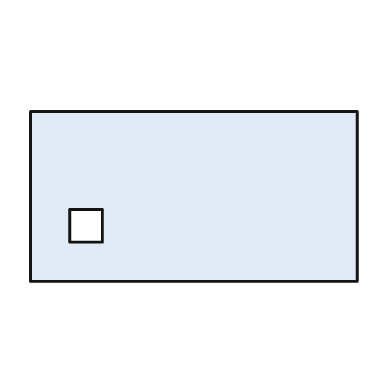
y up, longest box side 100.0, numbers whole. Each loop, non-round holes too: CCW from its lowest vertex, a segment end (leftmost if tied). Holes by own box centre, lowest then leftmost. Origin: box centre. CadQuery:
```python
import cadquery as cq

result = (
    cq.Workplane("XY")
    .moveTo(-50.0, -26.0)
    .lineTo(50.0, -26.0)
    .lineTo(50.0, 26.0)
    .lineTo(-50.0, 26.0)
    .close()
    .moveTo(-38.0, -14.0)
    .lineTo(-28.0, -14.0)
    .lineTo(-28.0, -4.0)
    .lineTo(-38.0, -4.0)
    .close()
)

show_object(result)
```